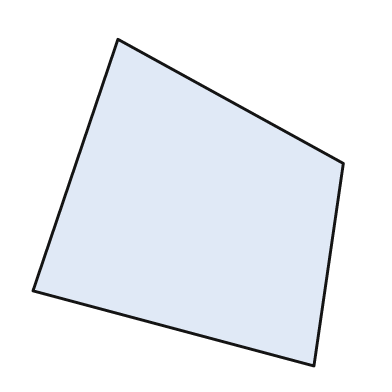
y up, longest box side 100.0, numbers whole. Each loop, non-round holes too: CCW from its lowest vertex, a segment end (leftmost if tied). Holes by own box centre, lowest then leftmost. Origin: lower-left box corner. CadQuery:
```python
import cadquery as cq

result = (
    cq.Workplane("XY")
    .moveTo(86.0, 0.0)
    .lineTo(95.0, 62.0)
    .lineTo(26.0, 100.0)
    .lineTo(0.0, 23.0)
    .close()
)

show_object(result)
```